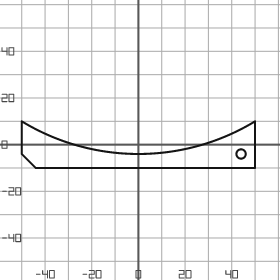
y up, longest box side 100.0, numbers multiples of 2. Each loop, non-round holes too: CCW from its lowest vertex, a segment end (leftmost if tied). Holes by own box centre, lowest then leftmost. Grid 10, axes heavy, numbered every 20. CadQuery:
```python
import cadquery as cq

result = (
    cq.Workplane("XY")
    .moveTo(-44.0, -10.0)
    .lineTo(50.0, -10.0)
    .lineTo(50.0, 10.0)
    .threePointArc((0.0, -4.0), (-50.0, 10.0))
    .lineTo(-50.0, -4.0)
    .close()
    .moveTo(44.0, -4.0)
    .circle(2.0)
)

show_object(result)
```